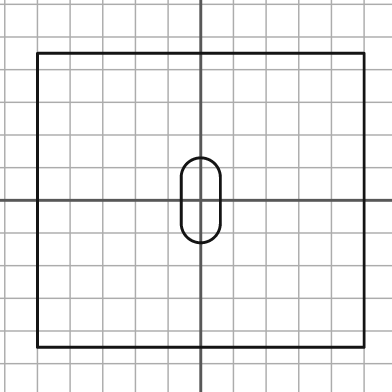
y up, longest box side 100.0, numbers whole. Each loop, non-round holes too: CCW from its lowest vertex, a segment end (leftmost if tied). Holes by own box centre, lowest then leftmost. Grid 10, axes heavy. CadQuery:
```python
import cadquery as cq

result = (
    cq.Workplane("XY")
    .moveTo(-50.0, -45.0)
    .lineTo(50.0, -45.0)
    .lineTo(50.0, 45.0)
    .lineTo(-50.0, 45.0)
    .close()
    .moveTo(-6.0, -7.0)
    .threePointArc((0.0, -13.0), (6.0, -7.0))
    .lineTo(6.0, 7.0)
    .threePointArc((0.0, 13.0), (-6.0, 7.0))
    .close()
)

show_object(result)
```